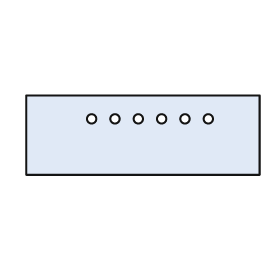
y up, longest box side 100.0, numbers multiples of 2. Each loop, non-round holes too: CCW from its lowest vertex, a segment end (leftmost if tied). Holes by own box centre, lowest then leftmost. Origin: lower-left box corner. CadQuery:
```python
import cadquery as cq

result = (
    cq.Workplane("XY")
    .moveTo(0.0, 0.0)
    .lineTo(100.0, 0.0)
    .lineTo(100.0, 34.0)
    .lineTo(0.0, 34.0)
    .close()
    .moveTo(28.0, 24.0)
    .circle(2.0)
    .moveTo(38.0, 24.0)
    .circle(2.0)
    .moveTo(48.0, 24.0)
    .circle(2.0)
    .moveTo(58.0, 24.0)
    .circle(2.0)
    .moveTo(68.0, 24.0)
    .circle(2.0)
    .moveTo(78.0, 24.0)
    .circle(2.0)
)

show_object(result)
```